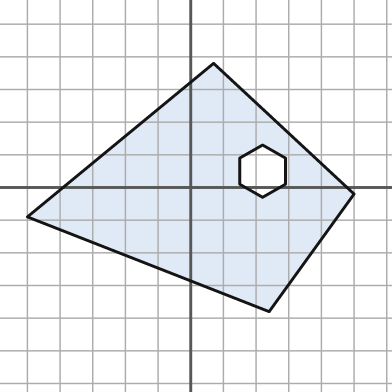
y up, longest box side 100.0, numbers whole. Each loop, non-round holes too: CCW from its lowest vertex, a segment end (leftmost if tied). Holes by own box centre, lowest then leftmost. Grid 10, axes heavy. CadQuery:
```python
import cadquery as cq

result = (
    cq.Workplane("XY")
    .moveTo(24.0, -38.0)
    .lineTo(50.0, -2.0)
    .lineTo(7.0, 38.0)
    .lineTo(-50.0, -9.0)
    .close()
    .moveTo(22.0, -3.0)
    .lineTo(29.0, 1.0)
    .lineTo(29.0, 9.0)
    .lineTo(22.0, 13.0)
    .lineTo(15.0, 9.0)
    .lineTo(15.0, 1.0)
    .close()
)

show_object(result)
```